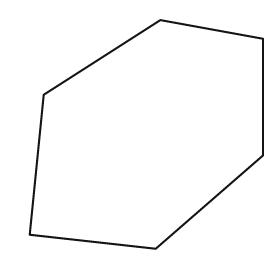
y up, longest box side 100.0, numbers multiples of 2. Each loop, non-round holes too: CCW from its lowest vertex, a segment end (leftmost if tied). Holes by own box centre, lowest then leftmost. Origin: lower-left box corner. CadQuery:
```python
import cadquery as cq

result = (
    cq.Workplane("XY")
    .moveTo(54.0, 0.0)
    .lineTo(100.0, 40.0)
    .lineTo(100.0, 90.0)
    .lineTo(56.0, 98.0)
    .lineTo(6.0, 66.0)
    .lineTo(0.0, 6.0)
    .close()
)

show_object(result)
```